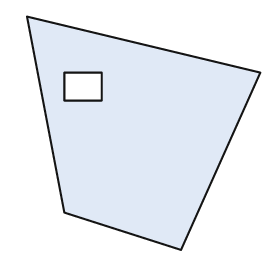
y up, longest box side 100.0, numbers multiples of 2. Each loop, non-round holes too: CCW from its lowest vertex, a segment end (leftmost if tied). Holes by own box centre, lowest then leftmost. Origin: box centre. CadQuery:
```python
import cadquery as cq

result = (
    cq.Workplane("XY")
    .moveTo(16.0, -50.0)
    .lineTo(50.0, 26.0)
    .lineTo(-50.0, 50.0)
    .lineTo(-34.0, -34.0)
    .close()
    .moveTo(-34.0, 14.0)
    .lineTo(-18.0, 14.0)
    .lineTo(-18.0, 26.0)
    .lineTo(-34.0, 26.0)
    .close()
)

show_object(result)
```